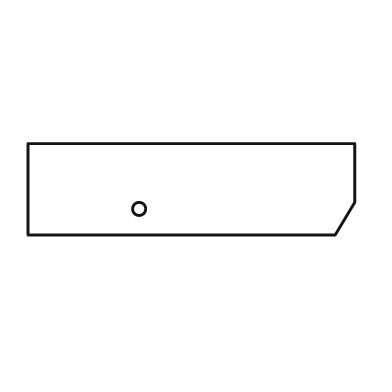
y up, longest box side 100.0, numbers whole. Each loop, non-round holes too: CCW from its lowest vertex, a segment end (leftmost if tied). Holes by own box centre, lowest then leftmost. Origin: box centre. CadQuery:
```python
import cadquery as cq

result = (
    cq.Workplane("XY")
    .moveTo(-50.0, -14.0)
    .lineTo(44.0, -14.0)
    .lineTo(50.0, -4.0)
    .lineTo(50.0, 14.0)
    .lineTo(-50.0, 14.0)
    .close()
    .moveTo(-16.0, -6.0)
    .circle(2.0)
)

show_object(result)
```